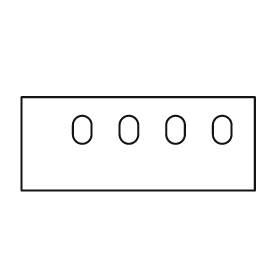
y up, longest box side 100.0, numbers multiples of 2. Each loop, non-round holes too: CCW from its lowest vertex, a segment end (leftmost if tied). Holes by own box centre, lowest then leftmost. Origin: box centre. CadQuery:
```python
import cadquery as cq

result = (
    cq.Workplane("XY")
    .moveTo(-50.0, -20.0)
    .lineTo(50.0, -20.0)
    .lineTo(50.0, 20.0)
    .lineTo(-50.0, 20.0)
    .close()
    .moveTo(-28.0, 4.0)
    .threePointArc((-24.0, 0.0), (-20.0, 4.0))
    .lineTo(-20.0, 8.0)
    .threePointArc((-24.0, 12.0), (-28.0, 8.0))
    .close()
    .moveTo(-8.0, 4.0)
    .threePointArc((-4.0, 0.0), (0.0, 4.0))
    .lineTo(0.0, 8.0)
    .threePointArc((-4.0, 12.0), (-8.0, 8.0))
    .close()
    .moveTo(12.0, 4.0)
    .threePointArc((16.0, 0.0), (20.0, 4.0))
    .lineTo(20.0, 8.0)
    .threePointArc((16.0, 12.0), (12.0, 8.0))
    .close()
    .moveTo(32.0, 4.0)
    .threePointArc((36.0, 0.0), (40.0, 4.0))
    .lineTo(40.0, 8.0)
    .threePointArc((36.0, 12.0), (32.0, 8.0))
    .close()
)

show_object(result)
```